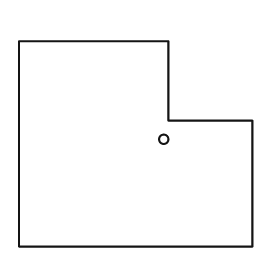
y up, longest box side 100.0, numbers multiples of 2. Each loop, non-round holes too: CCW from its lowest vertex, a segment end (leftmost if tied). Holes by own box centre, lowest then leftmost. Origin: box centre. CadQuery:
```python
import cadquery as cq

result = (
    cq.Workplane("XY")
    .moveTo(-50.0, -44.0)
    .lineTo(50.0, -44.0)
    .lineTo(50.0, 10.0)
    .lineTo(14.0, 10.0)
    .lineTo(14.0, 44.0)
    .lineTo(-50.0, 44.0)
    .close()
    .moveTo(12.0, 2.0)
    .circle(2.0)
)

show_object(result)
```